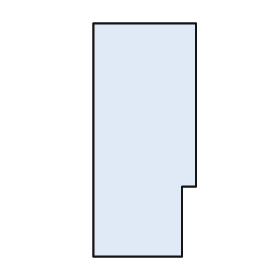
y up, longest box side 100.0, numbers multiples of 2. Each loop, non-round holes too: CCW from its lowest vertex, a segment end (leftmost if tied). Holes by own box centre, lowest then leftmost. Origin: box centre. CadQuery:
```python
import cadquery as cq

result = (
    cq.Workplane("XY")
    .moveTo(-22.0, -50.0)
    .lineTo(16.0, -50.0)
    .lineTo(16.0, -20.0)
    .lineTo(22.0, -20.0)
    .lineTo(22.0, 50.0)
    .lineTo(-22.0, 50.0)
    .close()
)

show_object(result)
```